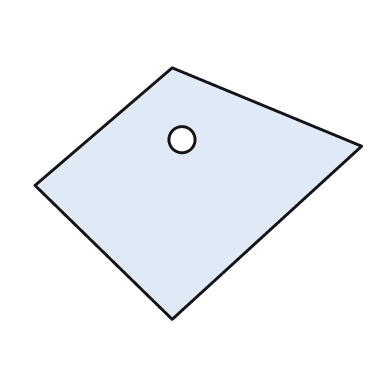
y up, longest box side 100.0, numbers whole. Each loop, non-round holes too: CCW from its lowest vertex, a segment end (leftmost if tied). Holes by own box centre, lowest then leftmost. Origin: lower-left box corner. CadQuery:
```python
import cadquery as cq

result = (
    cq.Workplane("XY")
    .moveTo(42.0, 0.0)
    .lineTo(100.0, 53.0)
    .lineTo(42.0, 77.0)
    .lineTo(0.0, 41.0)
    .close()
    .moveTo(45.0, 55.0)
    .circle(4.0)
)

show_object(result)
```